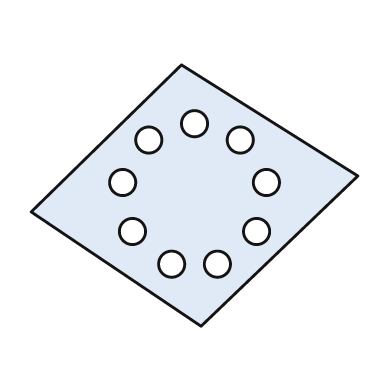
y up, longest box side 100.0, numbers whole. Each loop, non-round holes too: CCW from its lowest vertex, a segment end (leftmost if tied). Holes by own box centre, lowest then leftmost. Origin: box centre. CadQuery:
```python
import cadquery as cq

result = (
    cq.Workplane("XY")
    .moveTo(2.0, -40.0)
    .lineTo(50.0, 6.0)
    .lineTo(-4.0, 40.0)
    .lineTo(-50.0, -5.0)
    .close()
    .moveTo(-7.0, -21.0)
    .circle(4.0)
    .moveTo(7.0, -21.0)
    .circle(4.0)
    .moveTo(-19.0, -11.0)
    .circle(4.0)
    .moveTo(19.0, -11.0)
    .circle(4.0)
    .moveTo(-22.0, 4.0)
    .circle(4.0)
    .moveTo(22.0, 4.0)
    .circle(4.0)
    .moveTo(-14.0, 17.0)
    .circle(4.0)
    .moveTo(14.0, 17.0)
    .circle(4.0)
    .moveTo(0.0, 22.0)
    .circle(4.0)
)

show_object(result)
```